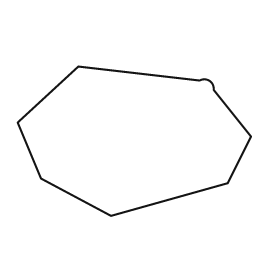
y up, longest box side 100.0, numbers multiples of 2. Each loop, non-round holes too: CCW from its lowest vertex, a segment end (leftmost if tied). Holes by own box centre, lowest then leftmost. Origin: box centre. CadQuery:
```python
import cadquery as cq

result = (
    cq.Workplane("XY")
    .moveTo(-10.0, -32.0)
    .lineTo(40.0, -18.0)
    .lineTo(50.0, 2.0)
    .lineTo(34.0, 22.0)
    .threePointArc((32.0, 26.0), (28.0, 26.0))
    .lineTo(-24.0, 32.0)
    .lineTo(-50.0, 8.0)
    .lineTo(-40.0, -16.0)
    .close()
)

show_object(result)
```